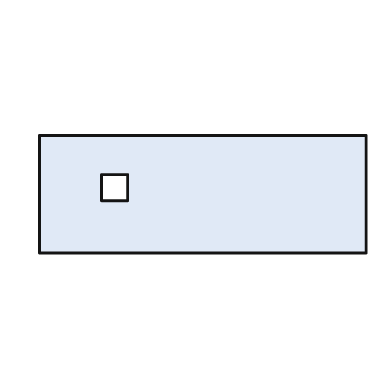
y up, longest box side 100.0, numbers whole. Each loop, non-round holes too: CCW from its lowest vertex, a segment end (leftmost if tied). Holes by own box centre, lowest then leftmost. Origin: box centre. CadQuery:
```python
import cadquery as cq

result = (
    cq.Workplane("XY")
    .moveTo(-50.0, -18.0)
    .lineTo(50.0, -18.0)
    .lineTo(50.0, 18.0)
    .lineTo(-50.0, 18.0)
    .close()
    .moveTo(-31.0, -2.0)
    .lineTo(-23.0, -2.0)
    .lineTo(-23.0, 6.0)
    .lineTo(-31.0, 6.0)
    .close()
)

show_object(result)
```